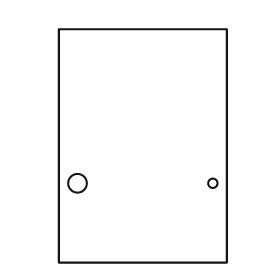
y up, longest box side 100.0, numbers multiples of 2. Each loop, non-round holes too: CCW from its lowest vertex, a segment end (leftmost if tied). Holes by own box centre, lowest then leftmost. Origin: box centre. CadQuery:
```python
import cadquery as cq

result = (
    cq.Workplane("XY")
    .moveTo(-36.0, -50.0)
    .lineTo(36.0, -50.0)
    .lineTo(36.0, 50.0)
    .lineTo(-36.0, 50.0)
    .close()
    .moveTo(-28.0, -16.0)
    .circle(4.0)
    .moveTo(30.0, -16.0)
    .circle(2.0)
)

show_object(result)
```